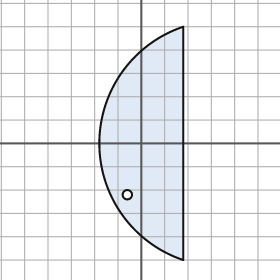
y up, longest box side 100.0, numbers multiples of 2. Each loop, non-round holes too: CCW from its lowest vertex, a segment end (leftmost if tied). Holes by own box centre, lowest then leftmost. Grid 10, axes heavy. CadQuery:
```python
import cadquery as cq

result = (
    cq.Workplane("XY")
    .moveTo(18.0, -50.0)
    .lineTo(18.0, 50.0)
    .threePointArc((-18.0, 0.0), (18.0, -50.0))
    .close()
    .moveTo(-6.0, -22.0)
    .circle(2.0)
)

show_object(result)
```